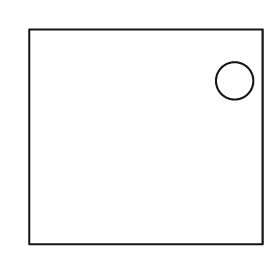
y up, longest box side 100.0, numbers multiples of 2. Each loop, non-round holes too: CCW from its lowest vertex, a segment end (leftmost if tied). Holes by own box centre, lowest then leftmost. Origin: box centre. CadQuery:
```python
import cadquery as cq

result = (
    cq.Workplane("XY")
    .moveTo(-50.0, -46.0)
    .lineTo(50.0, -46.0)
    .lineTo(50.0, 46.0)
    .lineTo(-50.0, 46.0)
    .close()
    .moveTo(38.0, 24.0)
    .circle(8.0)
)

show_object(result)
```